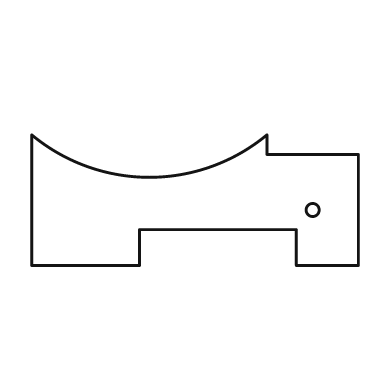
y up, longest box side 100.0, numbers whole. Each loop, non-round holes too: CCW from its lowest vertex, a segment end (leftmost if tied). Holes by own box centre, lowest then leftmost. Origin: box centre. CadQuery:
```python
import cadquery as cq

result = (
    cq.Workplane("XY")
    .moveTo(-50.0, -20.0)
    .lineTo(-17.0, -20.0)
    .lineTo(-17.0, -9.0)
    .lineTo(31.0, -9.0)
    .lineTo(31.0, -20.0)
    .lineTo(50.0, -20.0)
    .lineTo(50.0, 14.0)
    .lineTo(22.0, 14.0)
    .lineTo(22.0, 20.0)
    .threePointArc((-14.0, 7.0), (-50.0, 20.0))
    .close()
    .moveTo(36.0, -3.0)
    .circle(2.0)
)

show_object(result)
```